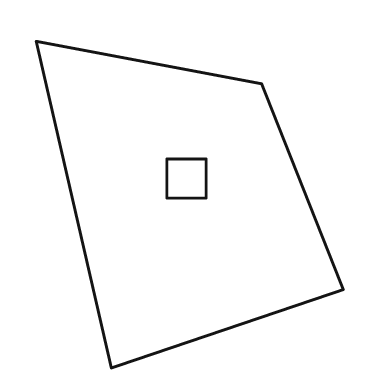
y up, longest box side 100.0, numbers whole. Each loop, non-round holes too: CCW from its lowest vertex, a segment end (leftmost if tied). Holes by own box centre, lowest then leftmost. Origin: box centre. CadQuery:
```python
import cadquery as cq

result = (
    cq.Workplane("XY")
    .moveTo(-24.0, -50.0)
    .lineTo(47.0, -26.0)
    .lineTo(22.0, 37.0)
    .lineTo(-47.0, 50.0)
    .close()
    .moveTo(-7.0, 2.0)
    .lineTo(5.0, 2.0)
    .lineTo(5.0, 14.0)
    .lineTo(-7.0, 14.0)
    .close()
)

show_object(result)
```